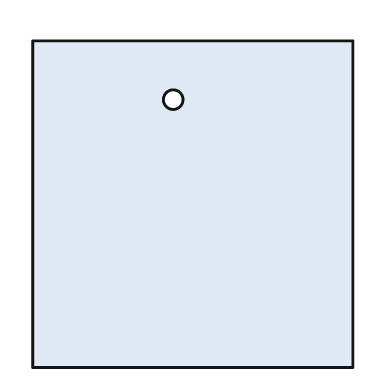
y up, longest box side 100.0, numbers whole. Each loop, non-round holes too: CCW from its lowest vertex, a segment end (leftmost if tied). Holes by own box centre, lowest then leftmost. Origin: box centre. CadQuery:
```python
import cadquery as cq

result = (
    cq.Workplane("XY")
    .moveTo(-49.0, -50.0)
    .lineTo(49.0, -50.0)
    .lineTo(49.0, 50.0)
    .lineTo(-49.0, 50.0)
    .close()
    .moveTo(-6.0, 32.0)
    .circle(3.0)
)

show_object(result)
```